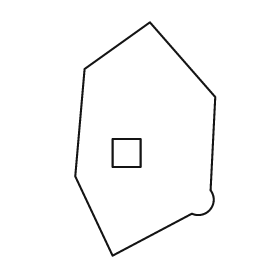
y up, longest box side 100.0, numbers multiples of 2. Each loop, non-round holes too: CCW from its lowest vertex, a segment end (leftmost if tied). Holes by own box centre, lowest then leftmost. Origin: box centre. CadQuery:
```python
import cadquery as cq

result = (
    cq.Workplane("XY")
    .moveTo(-14.0, -50.0)
    .lineTo(20.0, -32.0)
    .threePointArc((28.0, -30.0), (28.0, -22.0))
    .lineTo(30.0, 18.0)
    .lineTo(2.0, 50.0)
    .lineTo(-26.0, 30.0)
    .lineTo(-30.0, -16.0)
    .close()
    .moveTo(-14.0, -12.0)
    .lineTo(-2.0, -12.0)
    .lineTo(-2.0, 0.0)
    .lineTo(-14.0, 0.0)
    .close()
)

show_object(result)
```